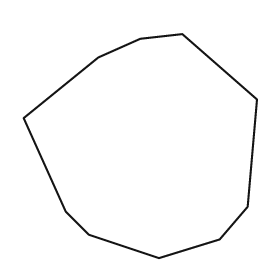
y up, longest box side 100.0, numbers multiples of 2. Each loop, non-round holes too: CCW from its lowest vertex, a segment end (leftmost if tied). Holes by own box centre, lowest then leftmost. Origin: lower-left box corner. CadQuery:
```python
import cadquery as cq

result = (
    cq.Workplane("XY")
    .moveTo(58.0, 0.0)
    .lineTo(84.0, 8.0)
    .lineTo(96.0, 22.0)
    .lineTo(100.0, 68.0)
    .lineTo(68.0, 96.0)
    .lineTo(50.0, 94.0)
    .lineTo(32.0, 86.0)
    .lineTo(0.0, 60.0)
    .lineTo(18.0, 20.0)
    .lineTo(28.0, 10.0)
    .close()
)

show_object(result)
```